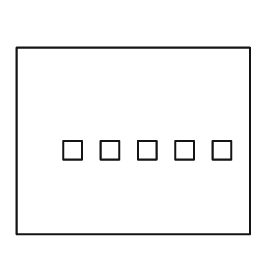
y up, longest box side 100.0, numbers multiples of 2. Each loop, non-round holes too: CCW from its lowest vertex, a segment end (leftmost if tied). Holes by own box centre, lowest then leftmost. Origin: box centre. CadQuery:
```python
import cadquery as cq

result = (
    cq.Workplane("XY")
    .moveTo(-50.0, -40.0)
    .lineTo(50.0, -40.0)
    .lineTo(50.0, 40.0)
    .lineTo(-50.0, 40.0)
    .close()
    .moveTo(-30.0, -8.0)
    .lineTo(-22.0, -8.0)
    .lineTo(-22.0, 0.0)
    .lineTo(-30.0, 0.0)
    .close()
    .moveTo(-14.0, -8.0)
    .lineTo(-6.0, -8.0)
    .lineTo(-6.0, 0.0)
    .lineTo(-14.0, 0.0)
    .close()
    .moveTo(2.0, -8.0)
    .lineTo(10.0, -8.0)
    .lineTo(10.0, 0.0)
    .lineTo(2.0, 0.0)
    .close()
    .moveTo(18.0, -8.0)
    .lineTo(26.0, -8.0)
    .lineTo(26.0, 0.0)
    .lineTo(18.0, 0.0)
    .close()
    .moveTo(34.0, -8.0)
    .lineTo(42.0, -8.0)
    .lineTo(42.0, 0.0)
    .lineTo(34.0, 0.0)
    .close()
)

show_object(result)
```